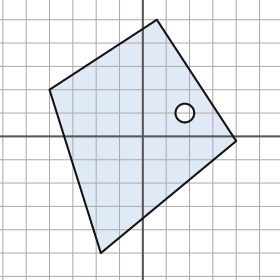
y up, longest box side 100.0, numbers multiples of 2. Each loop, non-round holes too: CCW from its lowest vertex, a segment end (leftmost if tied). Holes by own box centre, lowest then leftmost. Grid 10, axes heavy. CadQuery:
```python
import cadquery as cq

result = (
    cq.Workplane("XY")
    .moveTo(-18.0, -50.0)
    .lineTo(40.0, -2.0)
    .lineTo(6.0, 50.0)
    .lineTo(-40.0, 20.0)
    .close()
    .moveTo(18.0, 10.0)
    .circle(4.0)
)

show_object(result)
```